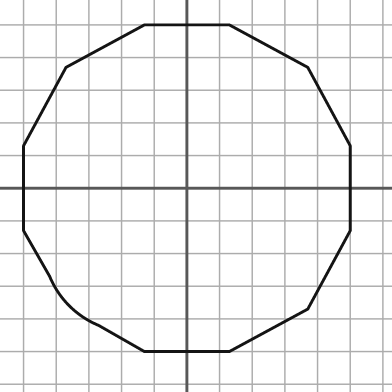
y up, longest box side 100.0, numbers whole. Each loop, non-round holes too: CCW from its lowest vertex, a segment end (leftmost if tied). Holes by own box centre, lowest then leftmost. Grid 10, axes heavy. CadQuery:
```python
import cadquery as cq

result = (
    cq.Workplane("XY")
    .moveTo(-13.0, -50.0)
    .lineTo(13.0, -50.0)
    .lineTo(37.0, -37.0)
    .lineTo(50.0, -13.0)
    .lineTo(50.0, 13.0)
    .lineTo(37.0, 37.0)
    .lineTo(13.0, 50.0)
    .lineTo(-13.0, 50.0)
    .lineTo(-37.0, 37.0)
    .lineTo(-50.0, 13.0)
    .lineTo(-50.0, -13.0)
    .lineTo(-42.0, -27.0)
    .threePointArc((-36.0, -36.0), (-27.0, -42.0))
    .close()
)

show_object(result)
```